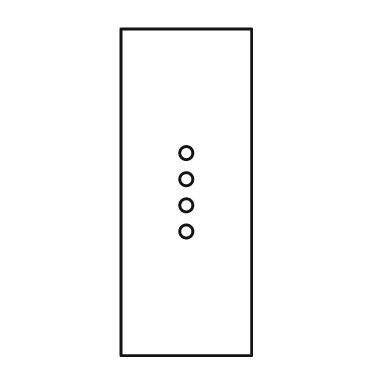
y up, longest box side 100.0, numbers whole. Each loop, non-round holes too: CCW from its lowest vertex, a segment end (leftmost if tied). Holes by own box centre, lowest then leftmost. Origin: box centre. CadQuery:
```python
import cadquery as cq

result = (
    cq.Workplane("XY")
    .moveTo(-20.0, -50.0)
    .lineTo(20.0, -50.0)
    .lineTo(20.0, 50.0)
    .lineTo(-20.0, 50.0)
    .close()
    .moveTo(0.0, -12.0)
    .circle(2.0)
    .moveTo(0.0, -4.0)
    .circle(2.0)
    .moveTo(0.0, 4.0)
    .circle(2.0)
    .moveTo(0.0, 12.0)
    .circle(2.0)
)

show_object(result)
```